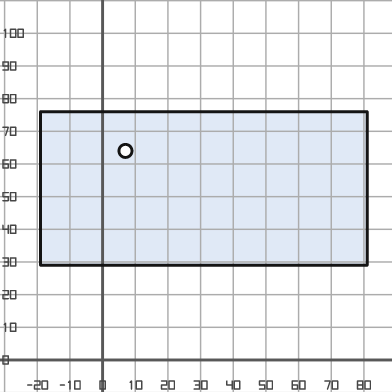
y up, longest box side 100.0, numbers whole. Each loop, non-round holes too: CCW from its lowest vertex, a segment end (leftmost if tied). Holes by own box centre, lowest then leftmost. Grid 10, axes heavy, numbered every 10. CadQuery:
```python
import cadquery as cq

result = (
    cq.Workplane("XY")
    .moveTo(-19.0, 29.0)
    .lineTo(81.0, 29.0)
    .lineTo(81.0, 76.0)
    .lineTo(-19.0, 76.0)
    .close()
    .moveTo(7.0, 64.0)
    .circle(2.0)
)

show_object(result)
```